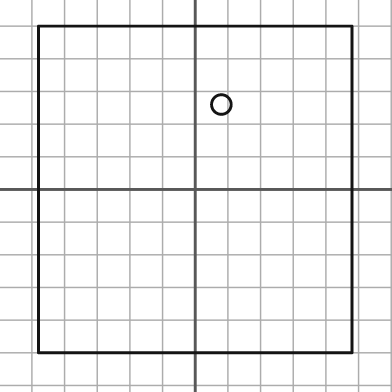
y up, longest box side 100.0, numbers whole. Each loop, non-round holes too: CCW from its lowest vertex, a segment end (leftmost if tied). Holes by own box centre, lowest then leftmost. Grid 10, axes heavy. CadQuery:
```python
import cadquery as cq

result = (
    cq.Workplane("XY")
    .moveTo(-48.0, -50.0)
    .lineTo(48.0, -50.0)
    .lineTo(48.0, 50.0)
    .lineTo(-48.0, 50.0)
    .close()
    .moveTo(8.0, 26.0)
    .circle(3.0)
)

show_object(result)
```